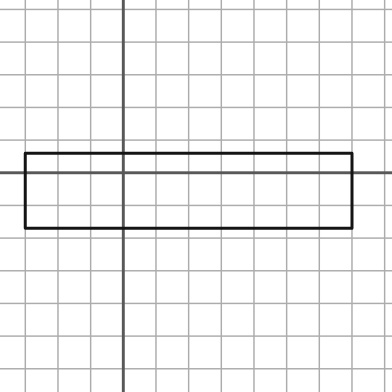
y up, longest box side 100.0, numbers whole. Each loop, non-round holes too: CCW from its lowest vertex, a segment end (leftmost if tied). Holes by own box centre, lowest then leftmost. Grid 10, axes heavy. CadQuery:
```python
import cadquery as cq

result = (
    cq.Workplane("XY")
    .moveTo(-30.0, -17.0)
    .lineTo(70.0, -17.0)
    .lineTo(70.0, 6.0)
    .lineTo(-30.0, 6.0)
    .close()
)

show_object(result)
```